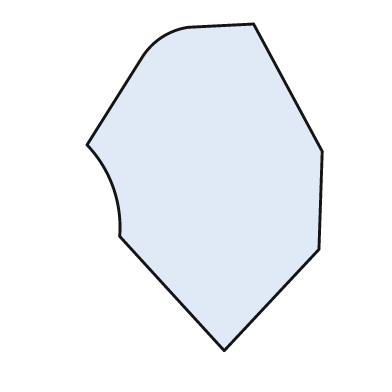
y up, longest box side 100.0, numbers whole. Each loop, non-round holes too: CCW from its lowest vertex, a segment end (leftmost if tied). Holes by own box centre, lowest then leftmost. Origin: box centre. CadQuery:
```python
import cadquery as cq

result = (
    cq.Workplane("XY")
    .moveTo(6.0, -50.0)
    .lineTo(35.0, -19.0)
    .lineTo(36.0, 11.0)
    .lineTo(15.0, 50.0)
    .lineTo(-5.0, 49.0)
    .threePointArc((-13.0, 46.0), (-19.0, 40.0))
    .lineTo(-36.0, 13.0)
    .threePointArc((-28.0, 0.0), (-26.0, -15.0))
    .close()
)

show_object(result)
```